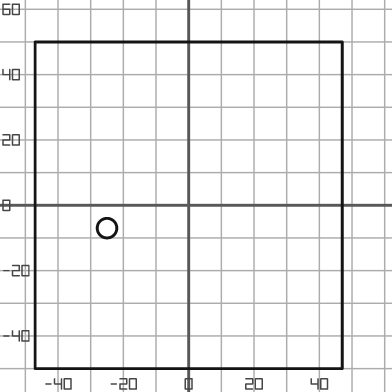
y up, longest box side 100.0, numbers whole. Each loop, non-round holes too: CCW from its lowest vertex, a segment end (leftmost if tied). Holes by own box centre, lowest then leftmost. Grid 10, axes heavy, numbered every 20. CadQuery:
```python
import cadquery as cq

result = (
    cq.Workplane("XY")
    .moveTo(-47.0, -50.0)
    .lineTo(47.0, -50.0)
    .lineTo(47.0, 50.0)
    .lineTo(-47.0, 50.0)
    .close()
    .moveTo(-25.0, -7.0)
    .circle(3.0)
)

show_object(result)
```